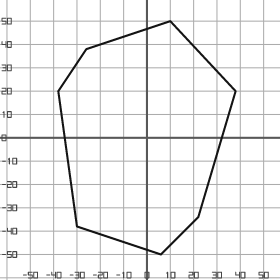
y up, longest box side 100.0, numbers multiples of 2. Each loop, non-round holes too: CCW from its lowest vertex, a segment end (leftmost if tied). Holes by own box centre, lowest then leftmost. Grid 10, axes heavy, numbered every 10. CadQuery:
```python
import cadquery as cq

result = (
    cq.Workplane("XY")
    .moveTo(6.0, -50.0)
    .lineTo(22.0, -34.0)
    .lineTo(38.0, 20.0)
    .lineTo(10.0, 50.0)
    .lineTo(-26.0, 38.0)
    .lineTo(-38.0, 20.0)
    .lineTo(-30.0, -38.0)
    .close()
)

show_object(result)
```